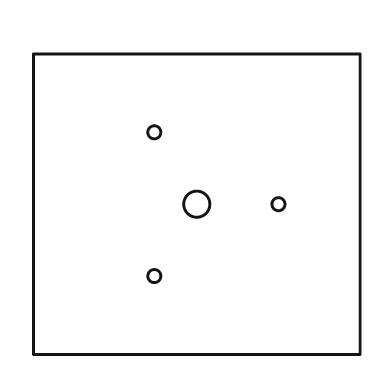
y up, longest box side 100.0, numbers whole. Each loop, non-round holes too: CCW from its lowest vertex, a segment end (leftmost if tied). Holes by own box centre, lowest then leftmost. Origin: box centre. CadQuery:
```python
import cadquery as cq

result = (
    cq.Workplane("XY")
    .moveTo(-50.0, -46.0)
    .lineTo(50.0, -46.0)
    .lineTo(50.0, 46.0)
    .lineTo(-50.0, 46.0)
    .close()
    .moveTo(-13.0, -22.0)
    .circle(2.0)
    .moveTo(0.0, 0.0)
    .circle(4.0)
    .moveTo(25.0, 0.0)
    .circle(2.0)
    .moveTo(-13.0, 22.0)
    .circle(2.0)
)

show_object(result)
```